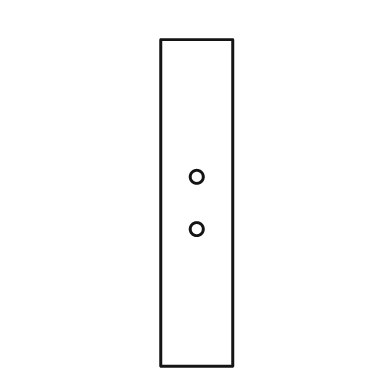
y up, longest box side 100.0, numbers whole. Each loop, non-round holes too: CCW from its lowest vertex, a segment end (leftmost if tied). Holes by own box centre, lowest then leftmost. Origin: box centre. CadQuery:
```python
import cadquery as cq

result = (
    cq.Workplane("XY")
    .moveTo(-11.0, -50.0)
    .lineTo(11.0, -50.0)
    .lineTo(11.0, 50.0)
    .lineTo(-11.0, 50.0)
    .close()
    .moveTo(0.0, -8.0)
    .circle(2.0)
    .moveTo(0.0, 8.0)
    .circle(2.0)
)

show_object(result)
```